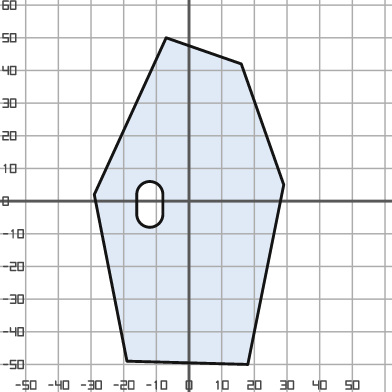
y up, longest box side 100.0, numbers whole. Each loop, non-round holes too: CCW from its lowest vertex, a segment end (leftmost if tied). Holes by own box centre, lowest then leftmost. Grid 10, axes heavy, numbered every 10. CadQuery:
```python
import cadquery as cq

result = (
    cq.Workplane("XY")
    .moveTo(18.0, -50.0)
    .lineTo(29.0, 5.0)
    .lineTo(16.0, 42.0)
    .lineTo(-7.0, 50.0)
    .lineTo(-29.0, 2.0)
    .lineTo(-19.0, -49.0)
    .close()
    .moveTo(-16.0, -4.0)
    .threePointArc((-12.0, -8.0), (-8.0, -4.0))
    .lineTo(-8.0, 2.0)
    .threePointArc((-12.0, 6.0), (-16.0, 2.0))
    .close()
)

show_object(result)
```